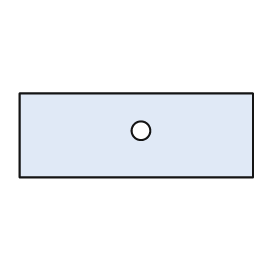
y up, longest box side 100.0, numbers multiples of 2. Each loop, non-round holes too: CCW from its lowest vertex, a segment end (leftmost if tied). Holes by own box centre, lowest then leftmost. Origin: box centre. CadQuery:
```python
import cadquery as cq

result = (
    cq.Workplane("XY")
    .moveTo(-50.0, -18.0)
    .lineTo(50.0, -18.0)
    .lineTo(50.0, 18.0)
    .lineTo(-50.0, 18.0)
    .close()
    .moveTo(2.0, 2.0)
    .circle(4.0)
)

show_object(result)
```